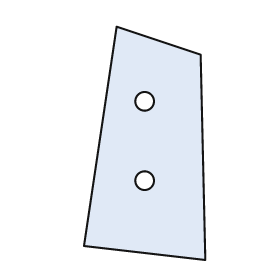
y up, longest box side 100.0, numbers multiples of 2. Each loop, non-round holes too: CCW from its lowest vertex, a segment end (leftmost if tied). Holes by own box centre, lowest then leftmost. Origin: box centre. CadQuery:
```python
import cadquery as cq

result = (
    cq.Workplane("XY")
    .moveTo(26.0, -50.0)
    .lineTo(24.0, 38.0)
    .lineTo(-12.0, 50.0)
    .lineTo(-26.0, -44.0)
    .close()
    .moveTo(0.0, -16.0)
    .circle(4.0)
    .moveTo(0.0, 18.0)
    .circle(4.0)
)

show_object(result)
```